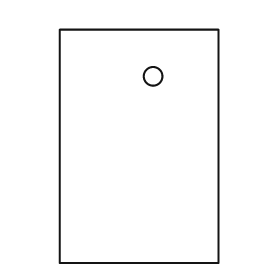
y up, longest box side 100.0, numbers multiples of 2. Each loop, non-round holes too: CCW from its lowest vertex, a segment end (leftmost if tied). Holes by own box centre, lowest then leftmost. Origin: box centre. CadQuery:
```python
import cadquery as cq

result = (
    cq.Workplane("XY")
    .moveTo(-34.0, -50.0)
    .lineTo(34.0, -50.0)
    .lineTo(34.0, 50.0)
    .lineTo(-34.0, 50.0)
    .close()
    .moveTo(6.0, 30.0)
    .circle(4.0)
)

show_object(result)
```